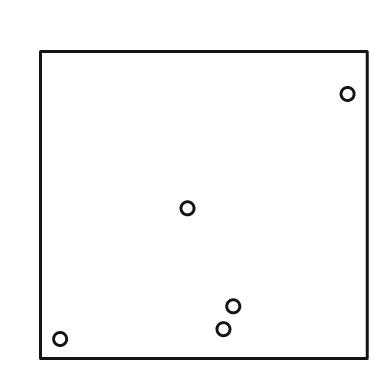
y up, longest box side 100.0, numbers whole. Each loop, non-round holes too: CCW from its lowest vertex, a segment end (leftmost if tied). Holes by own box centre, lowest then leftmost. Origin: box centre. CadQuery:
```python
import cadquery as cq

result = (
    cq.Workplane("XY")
    .moveTo(-50.0, -47.0)
    .lineTo(50.0, -47.0)
    .lineTo(50.0, 47.0)
    .lineTo(-50.0, 47.0)
    .close()
    .moveTo(-44.0, -41.0)
    .circle(2.0)
    .moveTo(6.0, -38.0)
    .circle(2.0)
    .moveTo(9.0, -31.0)
    .circle(2.0)
    .moveTo(-5.0, -1.0)
    .circle(2.0)
    .moveTo(44.0, 34.0)
    .circle(2.0)
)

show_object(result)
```